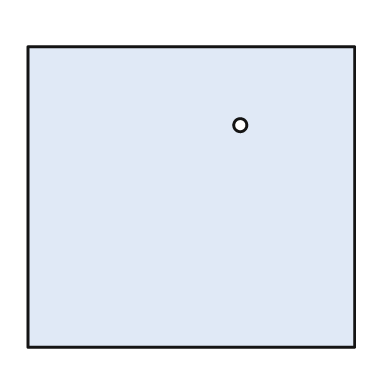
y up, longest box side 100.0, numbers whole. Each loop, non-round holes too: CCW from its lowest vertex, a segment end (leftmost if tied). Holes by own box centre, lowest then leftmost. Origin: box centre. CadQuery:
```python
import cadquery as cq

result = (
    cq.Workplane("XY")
    .moveTo(-50.0, -46.0)
    .lineTo(50.0, -46.0)
    .lineTo(50.0, 46.0)
    .lineTo(-50.0, 46.0)
    .close()
    .moveTo(15.0, 22.0)
    .circle(2.0)
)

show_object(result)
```